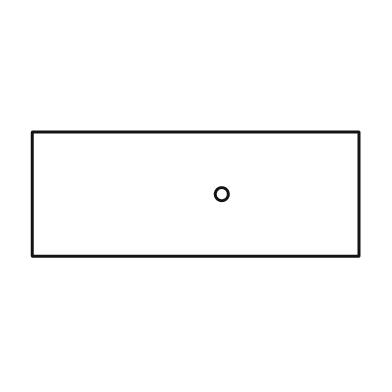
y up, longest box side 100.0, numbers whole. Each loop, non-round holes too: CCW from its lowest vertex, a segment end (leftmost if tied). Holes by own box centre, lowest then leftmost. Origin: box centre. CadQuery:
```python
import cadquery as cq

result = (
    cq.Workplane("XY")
    .moveTo(-50.0, -19.0)
    .lineTo(50.0, -19.0)
    .lineTo(50.0, 19.0)
    .lineTo(-50.0, 19.0)
    .close()
    .moveTo(8.0, 0.0)
    .circle(2.0)
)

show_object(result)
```